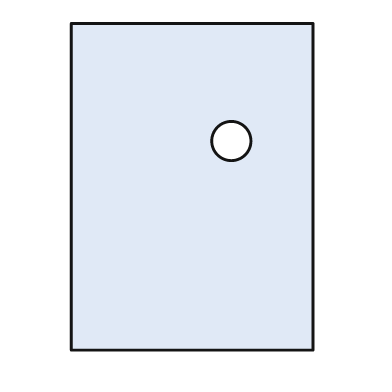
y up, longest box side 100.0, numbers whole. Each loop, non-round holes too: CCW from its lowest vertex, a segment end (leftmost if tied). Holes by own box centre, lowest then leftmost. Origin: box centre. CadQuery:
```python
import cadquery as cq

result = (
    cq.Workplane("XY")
    .moveTo(-37.0, -50.0)
    .lineTo(37.0, -50.0)
    .lineTo(37.0, 50.0)
    .lineTo(-37.0, 50.0)
    .close()
    .moveTo(12.0, 14.0)
    .circle(6.0)
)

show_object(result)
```